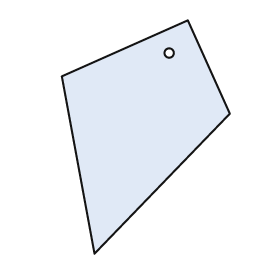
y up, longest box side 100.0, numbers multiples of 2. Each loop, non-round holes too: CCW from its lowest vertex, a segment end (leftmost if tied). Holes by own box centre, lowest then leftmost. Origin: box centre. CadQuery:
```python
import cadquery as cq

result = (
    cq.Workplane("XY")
    .moveTo(-22.0, -50.0)
    .lineTo(36.0, 10.0)
    .lineTo(18.0, 50.0)
    .lineTo(-36.0, 26.0)
    .close()
    .moveTo(10.0, 36.0)
    .circle(2.0)
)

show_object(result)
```